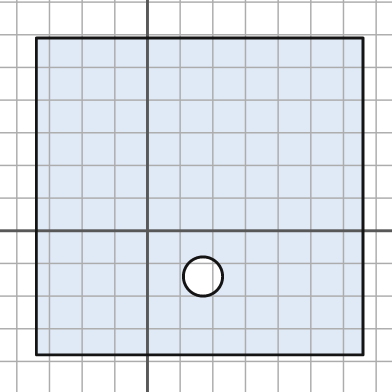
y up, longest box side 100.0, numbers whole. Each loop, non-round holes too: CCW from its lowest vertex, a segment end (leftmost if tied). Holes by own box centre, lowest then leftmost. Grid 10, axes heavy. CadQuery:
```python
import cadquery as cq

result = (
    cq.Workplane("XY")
    .moveTo(-34.0, -38.0)
    .lineTo(66.0, -38.0)
    .lineTo(66.0, 59.0)
    .lineTo(-34.0, 59.0)
    .close()
    .moveTo(17.0, -14.0)
    .circle(6.0)
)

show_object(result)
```